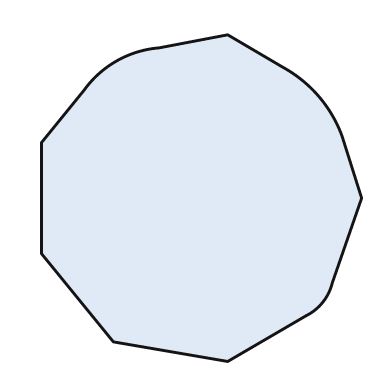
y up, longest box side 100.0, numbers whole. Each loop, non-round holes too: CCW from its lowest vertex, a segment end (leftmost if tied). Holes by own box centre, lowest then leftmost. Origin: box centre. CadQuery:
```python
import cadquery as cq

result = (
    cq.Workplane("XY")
    .moveTo(8.0, -50.0)
    .lineTo(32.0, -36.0)
    .threePointArc((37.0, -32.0), (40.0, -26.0))
    .lineTo(49.0, 0.0)
    .lineTo(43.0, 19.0)
    .threePointArc((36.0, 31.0), (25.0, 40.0))
    .lineTo(8.0, 50.0)
    .lineTo(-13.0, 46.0)
    .threePointArc((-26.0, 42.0), (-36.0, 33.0))
    .lineTo(-49.0, 17.0)
    .lineTo(-49.0, -17.0)
    .lineTo(-27.0, -44.0)
    .close()
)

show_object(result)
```